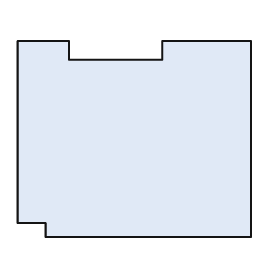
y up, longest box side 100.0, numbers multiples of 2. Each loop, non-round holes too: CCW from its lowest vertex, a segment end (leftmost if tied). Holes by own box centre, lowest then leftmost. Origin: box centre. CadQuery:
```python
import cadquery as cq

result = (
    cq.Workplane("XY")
    .moveTo(-38.0, -42.0)
    .lineTo(50.0, -42.0)
    .lineTo(50.0, 42.0)
    .lineTo(12.0, 42.0)
    .lineTo(12.0, 34.0)
    .lineTo(-28.0, 34.0)
    .lineTo(-28.0, 42.0)
    .lineTo(-50.0, 42.0)
    .lineTo(-50.0, -36.0)
    .lineTo(-38.0, -36.0)
    .close()
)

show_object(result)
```